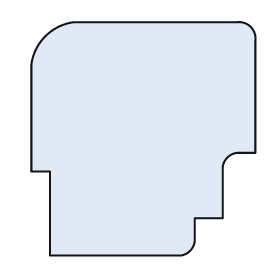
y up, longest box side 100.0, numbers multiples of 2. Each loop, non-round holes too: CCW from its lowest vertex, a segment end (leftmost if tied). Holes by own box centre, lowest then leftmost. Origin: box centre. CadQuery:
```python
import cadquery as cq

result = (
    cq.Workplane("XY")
    .moveTo(-40.0, -50.0)
    .lineTo(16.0, -50.0)
    .threePointArc((20.0, -48.0), (22.0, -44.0))
    .lineTo(22.0, -34.0)
    .lineTo(34.0, -34.0)
    .lineTo(34.0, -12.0)
    .threePointArc((36.0, -8.0), (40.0, -6.0))
    .lineTo(48.0, -6.0)
    .lineTo(48.0, 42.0)
    .threePointArc((46.0, 48.0), (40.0, 50.0))
    .lineTo(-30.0, 50.0)
    .threePointArc((-42.0, 44.0), (-48.0, 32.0))
    .lineTo(-48.0, -14.0)
    .lineTo(-40.0, -14.0)
    .close()
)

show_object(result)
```